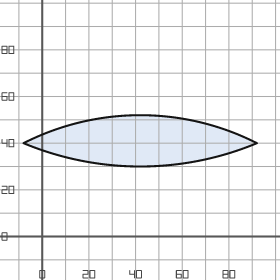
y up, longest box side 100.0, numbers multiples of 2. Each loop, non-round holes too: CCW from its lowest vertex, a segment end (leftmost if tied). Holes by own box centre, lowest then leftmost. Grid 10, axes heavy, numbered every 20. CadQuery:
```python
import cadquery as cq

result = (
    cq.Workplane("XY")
    .moveTo(-8.0, 40.0)
    .threePointArc((42.0, 30.0), (92.0, 40.0))
    .threePointArc((42.0, 52.0), (-8.0, 40.0))
    .close()
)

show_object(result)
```